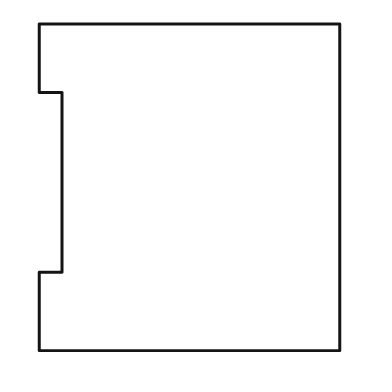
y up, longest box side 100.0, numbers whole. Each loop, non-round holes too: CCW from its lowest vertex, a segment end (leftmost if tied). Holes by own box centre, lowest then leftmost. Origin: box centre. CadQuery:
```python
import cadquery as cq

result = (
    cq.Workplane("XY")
    .moveTo(-46.0, -50.0)
    .lineTo(46.0, -50.0)
    .lineTo(46.0, 50.0)
    .lineTo(-46.0, 50.0)
    .lineTo(-46.0, 29.0)
    .lineTo(-39.0, 29.0)
    .lineTo(-39.0, -26.0)
    .lineTo(-46.0, -26.0)
    .close()
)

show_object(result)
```